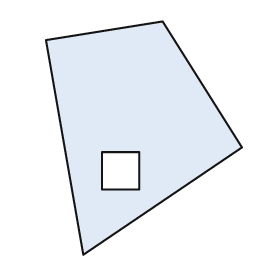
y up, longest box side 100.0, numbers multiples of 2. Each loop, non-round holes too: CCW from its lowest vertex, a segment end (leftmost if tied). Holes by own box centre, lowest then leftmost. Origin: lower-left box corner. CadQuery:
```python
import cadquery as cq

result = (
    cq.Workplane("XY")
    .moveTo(16.0, 0.0)
    .lineTo(84.0, 46.0)
    .lineTo(50.0, 100.0)
    .lineTo(0.0, 92.0)
    .close()
    .moveTo(24.0, 28.0)
    .lineTo(40.0, 28.0)
    .lineTo(40.0, 44.0)
    .lineTo(24.0, 44.0)
    .close()
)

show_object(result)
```